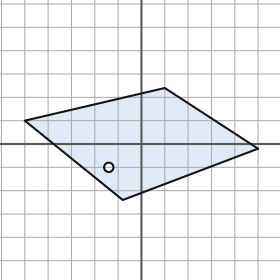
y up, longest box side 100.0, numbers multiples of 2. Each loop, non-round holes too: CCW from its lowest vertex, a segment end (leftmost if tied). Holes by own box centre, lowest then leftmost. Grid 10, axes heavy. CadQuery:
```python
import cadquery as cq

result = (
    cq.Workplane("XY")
    .moveTo(-8.0, -24.0)
    .lineTo(50.0, -2.0)
    .lineTo(10.0, 24.0)
    .lineTo(-50.0, 10.0)
    .close()
    .moveTo(-14.0, -10.0)
    .circle(2.0)
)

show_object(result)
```